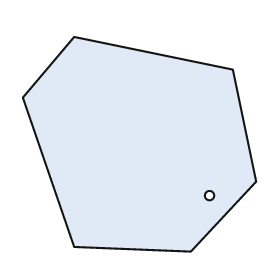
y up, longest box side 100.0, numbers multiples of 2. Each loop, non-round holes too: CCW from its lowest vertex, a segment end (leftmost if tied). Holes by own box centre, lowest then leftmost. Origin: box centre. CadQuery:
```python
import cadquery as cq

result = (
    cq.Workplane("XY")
    .moveTo(22.0, -46.0)
    .lineTo(50.0, -16.0)
    .lineTo(40.0, 32.0)
    .lineTo(-28.0, 46.0)
    .lineTo(-50.0, 20.0)
    .lineTo(-28.0, -44.0)
    .close()
    .moveTo(30.0, -22.0)
    .circle(2.0)
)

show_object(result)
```